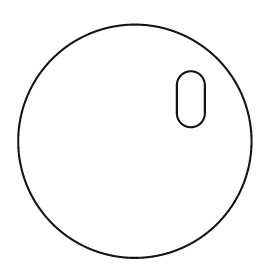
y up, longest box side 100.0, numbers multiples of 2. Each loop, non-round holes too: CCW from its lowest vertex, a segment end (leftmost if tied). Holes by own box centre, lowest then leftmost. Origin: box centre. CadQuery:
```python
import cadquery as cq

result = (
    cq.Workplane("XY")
    .moveTo(0.0, 0.0)
    .circle(50.0)
    .moveTo(18.0, 12.0)
    .threePointArc((24.0, 6.0), (30.0, 12.0))
    .lineTo(30.0, 24.0)
    .threePointArc((24.0, 30.0), (18.0, 24.0))
    .close()
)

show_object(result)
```